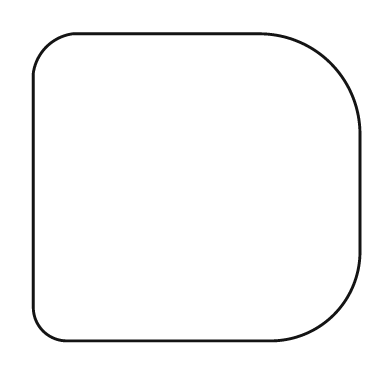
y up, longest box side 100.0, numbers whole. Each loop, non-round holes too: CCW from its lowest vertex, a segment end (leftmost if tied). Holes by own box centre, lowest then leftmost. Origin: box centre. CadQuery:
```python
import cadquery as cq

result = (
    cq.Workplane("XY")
    .moveTo(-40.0, -47.0)
    .lineTo(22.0, -47.0)
    .threePointArc((42.0, -39.0), (50.0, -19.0))
    .lineTo(50.0, 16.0)
    .threePointArc((41.0, 38.0), (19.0, 47.0))
    .lineTo(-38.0, 47.0)
    .threePointArc((-46.0, 43.0), (-50.0, 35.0))
    .lineTo(-50.0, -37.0)
    .threePointArc((-47.0, -44.0), (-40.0, -47.0))
    .close()
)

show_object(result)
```